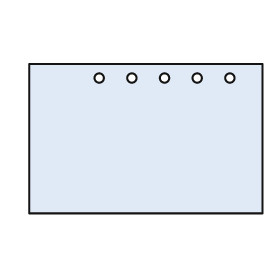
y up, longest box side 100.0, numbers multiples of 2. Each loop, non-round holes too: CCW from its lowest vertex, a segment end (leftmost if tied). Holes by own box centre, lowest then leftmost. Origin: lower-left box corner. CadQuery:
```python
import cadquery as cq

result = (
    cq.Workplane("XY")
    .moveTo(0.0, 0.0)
    .lineTo(100.0, 0.0)
    .lineTo(100.0, 64.0)
    .lineTo(0.0, 64.0)
    .close()
    .moveTo(30.0, 58.0)
    .circle(2.0)
    .moveTo(44.0, 58.0)
    .circle(2.0)
    .moveTo(58.0, 58.0)
    .circle(2.0)
    .moveTo(72.0, 58.0)
    .circle(2.0)
    .moveTo(86.0, 58.0)
    .circle(2.0)
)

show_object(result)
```